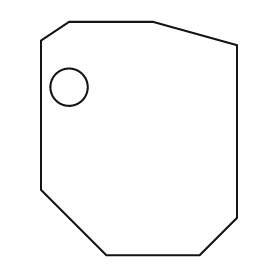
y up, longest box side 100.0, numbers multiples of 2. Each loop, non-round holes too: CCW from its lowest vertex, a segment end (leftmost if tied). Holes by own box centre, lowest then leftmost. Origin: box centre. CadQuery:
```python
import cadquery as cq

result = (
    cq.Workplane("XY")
    .moveTo(-14.0, -50.0)
    .lineTo(26.0, -50.0)
    .lineTo(42.0, -34.0)
    .lineTo(42.0, 40.0)
    .lineTo(6.0, 50.0)
    .lineTo(-30.0, 50.0)
    .lineTo(-42.0, 42.0)
    .lineTo(-42.0, -22.0)
    .close()
    .moveTo(-30.0, 22.0)
    .circle(8.0)
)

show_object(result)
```